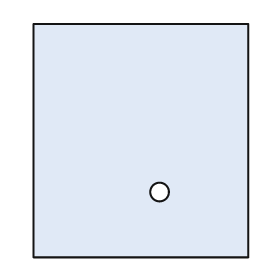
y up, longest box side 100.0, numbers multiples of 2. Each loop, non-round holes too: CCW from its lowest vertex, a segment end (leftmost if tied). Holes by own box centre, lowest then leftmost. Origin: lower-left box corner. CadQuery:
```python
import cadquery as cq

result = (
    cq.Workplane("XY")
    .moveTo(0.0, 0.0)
    .lineTo(92.0, 0.0)
    .lineTo(92.0, 100.0)
    .lineTo(0.0, 100.0)
    .close()
    .moveTo(54.0, 28.0)
    .circle(4.0)
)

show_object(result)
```